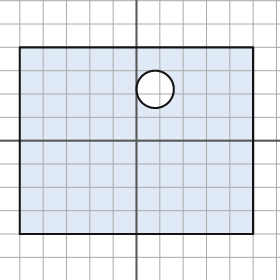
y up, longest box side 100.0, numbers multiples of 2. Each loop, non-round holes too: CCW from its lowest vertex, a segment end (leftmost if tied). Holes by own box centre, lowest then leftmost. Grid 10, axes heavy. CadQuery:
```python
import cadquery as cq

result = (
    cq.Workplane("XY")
    .moveTo(-50.0, -40.0)
    .lineTo(50.0, -40.0)
    .lineTo(50.0, 40.0)
    .lineTo(-50.0, 40.0)
    .close()
    .moveTo(8.0, 22.0)
    .circle(8.0)
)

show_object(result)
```